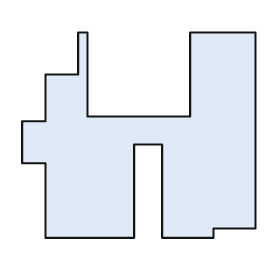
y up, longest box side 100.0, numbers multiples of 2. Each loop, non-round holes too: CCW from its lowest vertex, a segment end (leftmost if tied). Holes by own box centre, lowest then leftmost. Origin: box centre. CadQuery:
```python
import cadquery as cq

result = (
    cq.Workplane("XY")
    .moveTo(-40.0, -44.0)
    .lineTo(-2.0, -44.0)
    .lineTo(-2.0, -4.0)
    .lineTo(10.0, -4.0)
    .lineTo(10.0, -44.0)
    .lineTo(32.0, -44.0)
    .lineTo(32.0, -40.0)
    .lineTo(50.0, -40.0)
    .lineTo(50.0, 44.0)
    .lineTo(22.0, 44.0)
    .lineTo(22.0, 8.0)
    .lineTo(-22.0, 8.0)
    .lineTo(-22.0, 44.0)
    .lineTo(-26.0, 44.0)
    .lineTo(-26.0, 26.0)
    .lineTo(-40.0, 26.0)
    .lineTo(-40.0, 6.0)
    .lineTo(-50.0, 6.0)
    .lineTo(-50.0, -12.0)
    .lineTo(-40.0, -12.0)
    .close()
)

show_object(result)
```